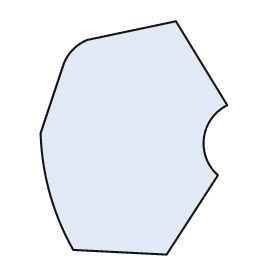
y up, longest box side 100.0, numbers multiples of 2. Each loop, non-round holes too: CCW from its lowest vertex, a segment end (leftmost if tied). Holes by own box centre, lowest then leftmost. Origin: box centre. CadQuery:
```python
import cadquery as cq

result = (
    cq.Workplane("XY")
    .moveTo(14.0, -50.0)
    .lineTo(36.0, -16.0)
    .threePointArc((30.0, 0.0), (40.0, 14.0))
    .lineTo(18.0, 50.0)
    .lineTo(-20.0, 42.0)
    .threePointArc((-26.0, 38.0), (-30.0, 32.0))
    .lineTo(-40.0, 2.0)
    .threePointArc((-36.0, -24.0), (-26.0, -48.0))
    .close()
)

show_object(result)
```